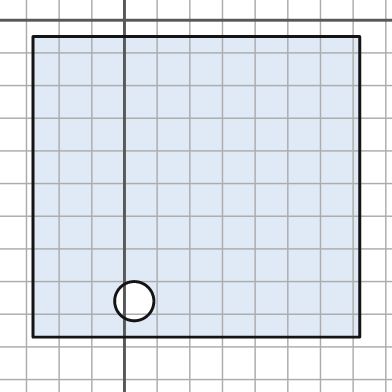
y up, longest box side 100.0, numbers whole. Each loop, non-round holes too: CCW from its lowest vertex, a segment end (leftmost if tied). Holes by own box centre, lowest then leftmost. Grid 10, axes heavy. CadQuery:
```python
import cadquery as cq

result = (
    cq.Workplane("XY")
    .moveTo(-28.0, -97.0)
    .lineTo(72.0, -97.0)
    .lineTo(72.0, -5.0)
    .lineTo(-28.0, -5.0)
    .close()
    .moveTo(3.0, -86.0)
    .circle(6.0)
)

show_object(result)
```